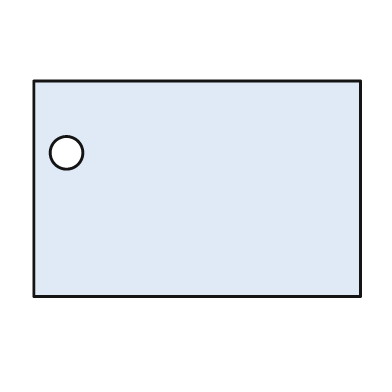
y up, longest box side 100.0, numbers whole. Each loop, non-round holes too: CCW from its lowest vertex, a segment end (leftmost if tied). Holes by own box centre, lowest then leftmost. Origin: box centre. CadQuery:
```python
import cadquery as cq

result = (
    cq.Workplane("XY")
    .moveTo(-50.0, -33.0)
    .lineTo(50.0, -33.0)
    .lineTo(50.0, 33.0)
    .lineTo(-50.0, 33.0)
    .close()
    .moveTo(-40.0, 11.0)
    .circle(5.0)
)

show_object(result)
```